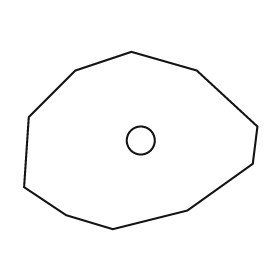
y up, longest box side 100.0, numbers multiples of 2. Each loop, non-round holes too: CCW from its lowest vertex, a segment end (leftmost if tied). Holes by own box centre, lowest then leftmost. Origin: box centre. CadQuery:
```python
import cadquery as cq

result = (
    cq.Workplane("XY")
    .moveTo(-12.0, -38.0)
    .lineTo(20.0, -30.0)
    .lineTo(48.0, -10.0)
    .lineTo(50.0, 6.0)
    .lineTo(24.0, 30.0)
    .lineTo(-4.0, 38.0)
    .lineTo(-28.0, 30.0)
    .lineTo(-48.0, 10.0)
    .lineTo(-50.0, -20.0)
    .lineTo(-32.0, -32.0)
    .close()
    .moveTo(0.0, 0.0)
    .circle(6.0)
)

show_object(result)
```